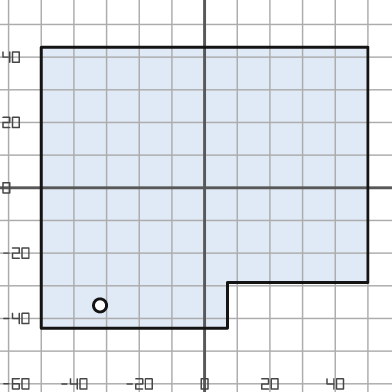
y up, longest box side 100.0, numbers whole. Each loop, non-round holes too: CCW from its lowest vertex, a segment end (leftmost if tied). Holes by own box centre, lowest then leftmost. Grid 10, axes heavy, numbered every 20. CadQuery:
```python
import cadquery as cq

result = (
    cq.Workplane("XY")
    .moveTo(-50.0, -43.0)
    .lineTo(7.0, -43.0)
    .lineTo(7.0, -29.0)
    .lineTo(50.0, -29.0)
    .lineTo(50.0, 43.0)
    .lineTo(-50.0, 43.0)
    .close()
    .moveTo(-32.0, -36.0)
    .circle(2.0)
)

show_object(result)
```